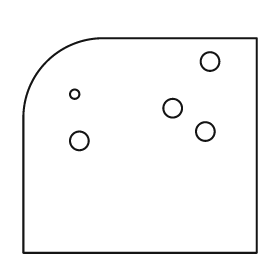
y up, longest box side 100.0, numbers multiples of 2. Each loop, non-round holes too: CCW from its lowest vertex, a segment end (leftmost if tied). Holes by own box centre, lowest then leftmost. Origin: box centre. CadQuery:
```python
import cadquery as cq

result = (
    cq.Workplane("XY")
    .moveTo(-50.0, -46.0)
    .lineTo(50.0, -46.0)
    .lineTo(50.0, 46.0)
    .lineTo(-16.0, 46.0)
    .threePointArc((-40.0, 36.0), (-50.0, 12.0))
    .close()
    .moveTo(-26.0, 2.0)
    .circle(4.0)
    .moveTo(28.0, 6.0)
    .circle(4.0)
    .moveTo(14.0, 16.0)
    .circle(4.0)
    .moveTo(-28.0, 22.0)
    .circle(2.0)
    .moveTo(30.0, 36.0)
    .circle(4.0)
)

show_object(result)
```